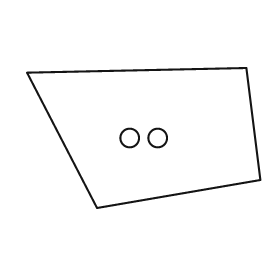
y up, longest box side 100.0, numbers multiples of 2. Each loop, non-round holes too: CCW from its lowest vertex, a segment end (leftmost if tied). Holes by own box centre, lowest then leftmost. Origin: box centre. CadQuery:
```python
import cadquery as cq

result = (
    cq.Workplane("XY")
    .moveTo(-20.0, -30.0)
    .lineTo(50.0, -18.0)
    .lineTo(44.0, 30.0)
    .lineTo(-50.0, 28.0)
    .close()
    .moveTo(-6.0, 0.0)
    .circle(4.0)
    .moveTo(6.0, 0.0)
    .circle(4.0)
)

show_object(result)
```